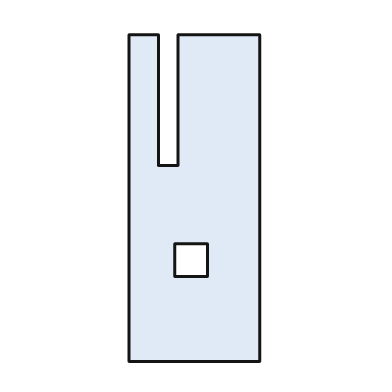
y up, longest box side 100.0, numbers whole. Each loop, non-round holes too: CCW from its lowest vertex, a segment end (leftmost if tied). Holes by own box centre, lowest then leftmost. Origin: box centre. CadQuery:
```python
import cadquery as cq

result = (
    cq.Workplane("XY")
    .moveTo(-20.0, -50.0)
    .lineTo(20.0, -50.0)
    .lineTo(20.0, 50.0)
    .lineTo(-5.0, 50.0)
    .lineTo(-5.0, 10.0)
    .lineTo(-11.0, 10.0)
    .lineTo(-11.0, 50.0)
    .lineTo(-20.0, 50.0)
    .close()
    .moveTo(-6.0, -24.0)
    .lineTo(4.0, -24.0)
    .lineTo(4.0, -14.0)
    .lineTo(-6.0, -14.0)
    .close()
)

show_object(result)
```